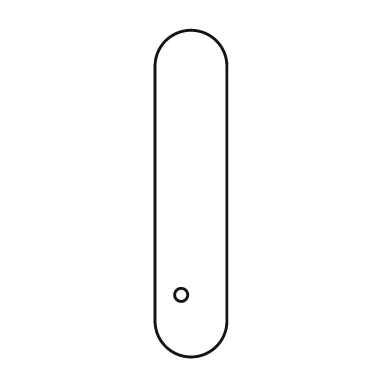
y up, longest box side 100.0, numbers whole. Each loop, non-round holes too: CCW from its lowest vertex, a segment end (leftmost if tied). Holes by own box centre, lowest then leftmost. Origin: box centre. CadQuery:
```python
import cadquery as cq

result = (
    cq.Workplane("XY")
    .moveTo(-11.0, -39.0)
    .threePointArc((0.0, -50.0), (11.0, -39.0))
    .lineTo(11.0, 39.0)
    .threePointArc((0.0, 50.0), (-11.0, 39.0))
    .close()
    .moveTo(-3.0, -31.0)
    .circle(2.0)
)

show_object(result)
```